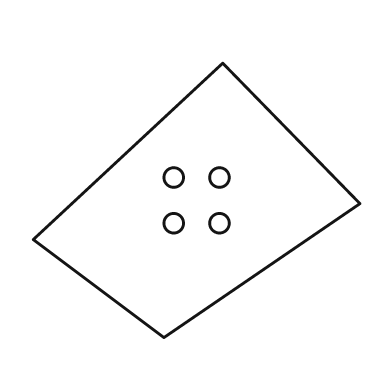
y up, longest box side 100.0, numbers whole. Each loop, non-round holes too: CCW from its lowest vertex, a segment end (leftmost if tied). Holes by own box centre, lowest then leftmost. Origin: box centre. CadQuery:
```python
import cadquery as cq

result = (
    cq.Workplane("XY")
    .moveTo(-10.0, -42.0)
    .lineTo(50.0, -1.0)
    .lineTo(8.0, 42.0)
    .lineTo(-50.0, -12.0)
    .close()
    .moveTo(-7.0, -7.0)
    .circle(3.0)
    .moveTo(7.0, -7.0)
    .circle(3.0)
    .moveTo(-7.0, 7.0)
    .circle(3.0)
    .moveTo(7.0, 7.0)
    .circle(3.0)
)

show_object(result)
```